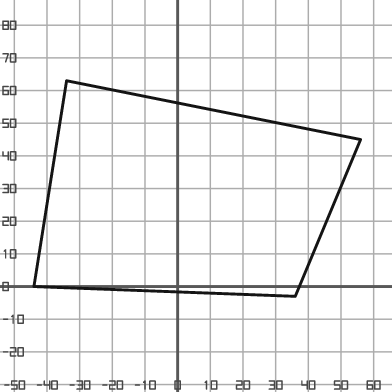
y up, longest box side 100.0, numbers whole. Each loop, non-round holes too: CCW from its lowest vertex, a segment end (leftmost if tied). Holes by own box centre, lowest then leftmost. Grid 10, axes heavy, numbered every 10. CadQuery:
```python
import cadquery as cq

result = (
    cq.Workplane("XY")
    .moveTo(36.0, -3.0)
    .lineTo(56.0, 45.0)
    .lineTo(-34.0, 63.0)
    .lineTo(-44.0, 0.0)
    .close()
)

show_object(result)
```